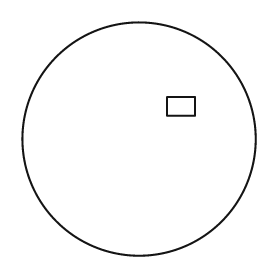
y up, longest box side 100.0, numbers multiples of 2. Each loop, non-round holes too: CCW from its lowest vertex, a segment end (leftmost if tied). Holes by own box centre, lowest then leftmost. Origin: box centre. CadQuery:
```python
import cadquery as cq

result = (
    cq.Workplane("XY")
    .moveTo(0.0, 0.0)
    .circle(50.0)
    .moveTo(12.0, 10.0)
    .lineTo(24.0, 10.0)
    .lineTo(24.0, 18.0)
    .lineTo(12.0, 18.0)
    .close()
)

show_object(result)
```